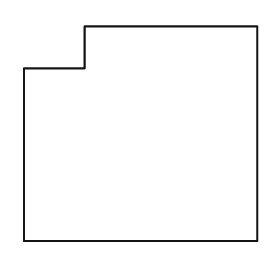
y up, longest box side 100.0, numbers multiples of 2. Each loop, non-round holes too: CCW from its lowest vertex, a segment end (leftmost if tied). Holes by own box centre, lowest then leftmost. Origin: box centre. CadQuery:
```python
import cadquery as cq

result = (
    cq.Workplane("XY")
    .moveTo(-50.0, -46.0)
    .lineTo(50.0, -46.0)
    .lineTo(50.0, 46.0)
    .lineTo(-24.0, 46.0)
    .lineTo(-24.0, 28.0)
    .lineTo(-50.0, 28.0)
    .close()
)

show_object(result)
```